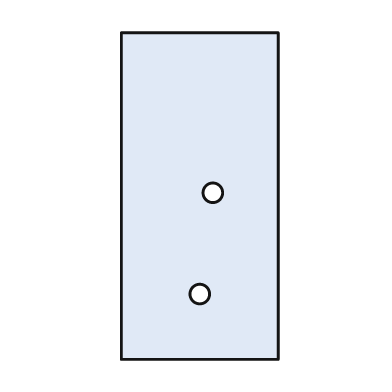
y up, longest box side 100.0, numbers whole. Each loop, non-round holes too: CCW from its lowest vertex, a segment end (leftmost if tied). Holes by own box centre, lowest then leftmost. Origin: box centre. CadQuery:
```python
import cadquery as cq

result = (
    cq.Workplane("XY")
    .moveTo(-24.0, -50.0)
    .lineTo(24.0, -50.0)
    .lineTo(24.0, 50.0)
    .lineTo(-24.0, 50.0)
    .close()
    .moveTo(0.0, -30.0)
    .circle(3.0)
    .moveTo(4.0, 1.0)
    .circle(3.0)
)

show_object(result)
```